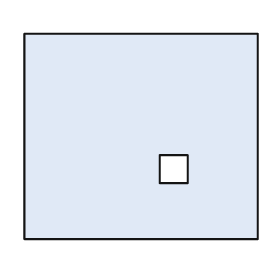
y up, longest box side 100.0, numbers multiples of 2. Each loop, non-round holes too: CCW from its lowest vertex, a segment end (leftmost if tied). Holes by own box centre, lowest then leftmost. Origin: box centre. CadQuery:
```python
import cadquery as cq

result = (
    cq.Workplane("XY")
    .moveTo(-50.0, -44.0)
    .lineTo(50.0, -44.0)
    .lineTo(50.0, 44.0)
    .lineTo(-50.0, 44.0)
    .close()
    .moveTo(8.0, -20.0)
    .lineTo(20.0, -20.0)
    .lineTo(20.0, -8.0)
    .lineTo(8.0, -8.0)
    .close()
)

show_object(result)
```